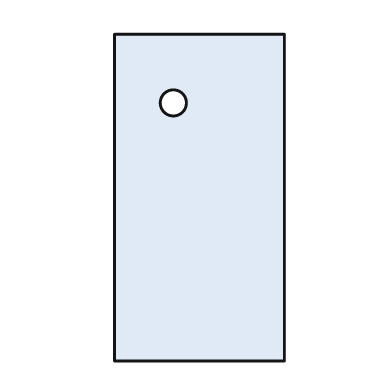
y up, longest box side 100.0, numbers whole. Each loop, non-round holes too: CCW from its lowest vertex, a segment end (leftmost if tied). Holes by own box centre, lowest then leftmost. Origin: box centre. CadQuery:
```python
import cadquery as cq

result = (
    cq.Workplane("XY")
    .moveTo(-26.0, -50.0)
    .lineTo(26.0, -50.0)
    .lineTo(26.0, 50.0)
    .lineTo(-26.0, 50.0)
    .close()
    .moveTo(-8.0, 29.0)
    .circle(4.0)
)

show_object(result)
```